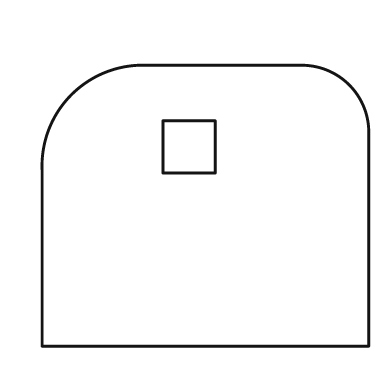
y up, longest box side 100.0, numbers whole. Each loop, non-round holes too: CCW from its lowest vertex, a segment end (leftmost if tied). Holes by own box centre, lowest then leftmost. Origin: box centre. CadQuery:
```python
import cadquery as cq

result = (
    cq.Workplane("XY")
    .moveTo(-50.0, -43.0)
    .lineTo(50.0, -43.0)
    .lineTo(50.0, 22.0)
    .threePointArc((44.0, 37.0), (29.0, 43.0))
    .lineTo(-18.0, 43.0)
    .threePointArc((-41.0, 34.0), (-50.0, 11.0))
    .close()
    .moveTo(-13.0, 10.0)
    .lineTo(3.0, 10.0)
    .lineTo(3.0, 26.0)
    .lineTo(-13.0, 26.0)
    .close()
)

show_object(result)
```